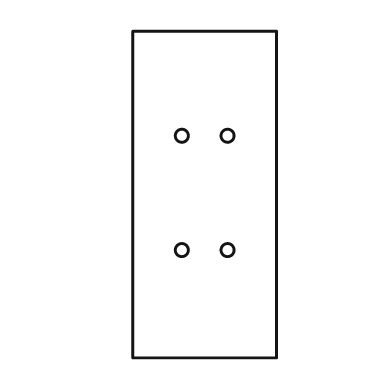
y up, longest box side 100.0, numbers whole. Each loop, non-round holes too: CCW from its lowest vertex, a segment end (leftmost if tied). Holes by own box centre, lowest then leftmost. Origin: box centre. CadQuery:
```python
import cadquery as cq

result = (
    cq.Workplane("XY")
    .moveTo(-22.0, -50.0)
    .lineTo(22.0, -50.0)
    .lineTo(22.0, 50.0)
    .lineTo(-22.0, 50.0)
    .close()
    .moveTo(-7.0, -17.0)
    .circle(2.0)
    .moveTo(7.0, -17.0)
    .circle(2.0)
    .moveTo(-7.0, 18.0)
    .circle(2.0)
    .moveTo(7.0, 18.0)
    .circle(2.0)
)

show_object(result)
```